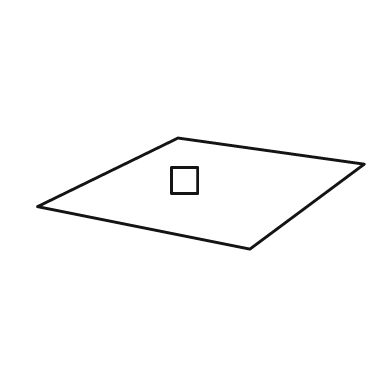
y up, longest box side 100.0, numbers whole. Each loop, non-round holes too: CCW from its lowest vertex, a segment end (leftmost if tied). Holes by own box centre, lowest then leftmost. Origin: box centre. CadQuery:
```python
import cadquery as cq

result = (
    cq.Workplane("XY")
    .moveTo(15.0, -17.0)
    .lineTo(50.0, 9.0)
    .lineTo(-7.0, 17.0)
    .lineTo(-50.0, -4.0)
    .close()
    .moveTo(-9.0, 0.0)
    .lineTo(-1.0, 0.0)
    .lineTo(-1.0, 8.0)
    .lineTo(-9.0, 8.0)
    .close()
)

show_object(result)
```